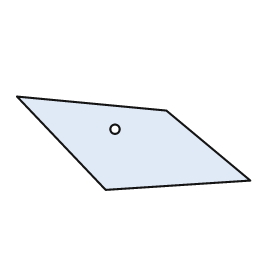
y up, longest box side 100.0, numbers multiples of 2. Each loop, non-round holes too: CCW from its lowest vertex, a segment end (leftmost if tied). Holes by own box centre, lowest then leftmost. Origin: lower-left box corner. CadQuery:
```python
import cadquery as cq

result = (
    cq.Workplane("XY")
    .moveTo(38.0, 0.0)
    .lineTo(100.0, 4.0)
    .lineTo(64.0, 34.0)
    .lineTo(0.0, 40.0)
    .close()
    .moveTo(42.0, 26.0)
    .circle(2.0)
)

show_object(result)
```